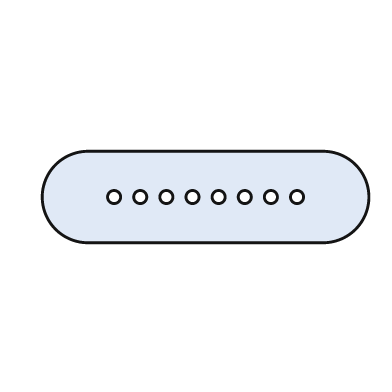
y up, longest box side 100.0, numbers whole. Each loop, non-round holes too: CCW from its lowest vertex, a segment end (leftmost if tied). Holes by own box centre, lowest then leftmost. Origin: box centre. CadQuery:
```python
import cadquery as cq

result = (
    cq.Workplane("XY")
    .moveTo(-36.0, -14.0)
    .lineTo(36.0, -14.0)
    .threePointArc((50.0, 0.0), (36.0, 14.0))
    .lineTo(-36.0, 14.0)
    .threePointArc((-50.0, 0.0), (-36.0, -14.0))
    .close()
    .moveTo(-28.0, 0.0)
    .circle(2.0)
    .moveTo(-20.0, 0.0)
    .circle(2.0)
    .moveTo(-12.0, 0.0)
    .circle(2.0)
    .moveTo(-4.0, 0.0)
    .circle(2.0)
    .moveTo(4.0, 0.0)
    .circle(2.0)
    .moveTo(12.0, 0.0)
    .circle(2.0)
    .moveTo(20.0, 0.0)
    .circle(2.0)
    .moveTo(28.0, 0.0)
    .circle(2.0)
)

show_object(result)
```